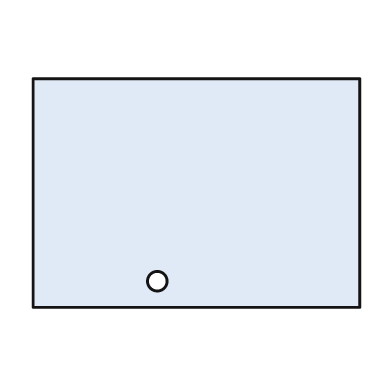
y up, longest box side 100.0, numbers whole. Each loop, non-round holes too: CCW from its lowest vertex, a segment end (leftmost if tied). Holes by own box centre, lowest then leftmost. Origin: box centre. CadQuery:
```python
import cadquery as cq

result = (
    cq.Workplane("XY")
    .moveTo(-50.0, -35.0)
    .lineTo(50.0, -35.0)
    .lineTo(50.0, 35.0)
    .lineTo(-50.0, 35.0)
    .close()
    .moveTo(-12.0, -27.0)
    .circle(3.0)
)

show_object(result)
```